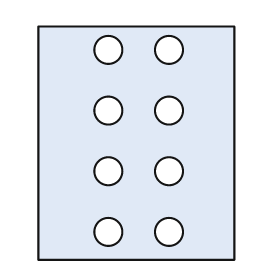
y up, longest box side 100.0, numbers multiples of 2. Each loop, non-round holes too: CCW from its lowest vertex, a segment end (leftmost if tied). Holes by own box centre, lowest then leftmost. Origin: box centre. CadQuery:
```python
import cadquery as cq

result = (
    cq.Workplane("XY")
    .moveTo(-42.0, -50.0)
    .lineTo(42.0, -50.0)
    .lineTo(42.0, 50.0)
    .lineTo(-42.0, 50.0)
    .close()
    .moveTo(-12.0, -38.0)
    .circle(6.0)
    .moveTo(14.0, -38.0)
    .circle(6.0)
    .moveTo(-12.0, -12.0)
    .circle(6.0)
    .moveTo(14.0, -12.0)
    .circle(6.0)
    .moveTo(-12.0, 14.0)
    .circle(6.0)
    .moveTo(14.0, 14.0)
    .circle(6.0)
    .moveTo(-12.0, 40.0)
    .circle(6.0)
    .moveTo(14.0, 40.0)
    .circle(6.0)
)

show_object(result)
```